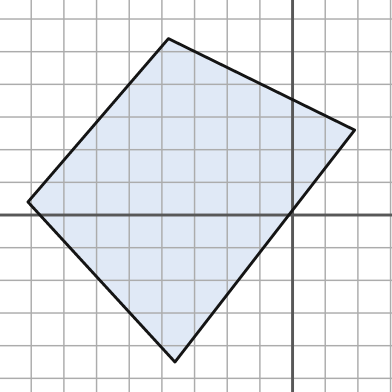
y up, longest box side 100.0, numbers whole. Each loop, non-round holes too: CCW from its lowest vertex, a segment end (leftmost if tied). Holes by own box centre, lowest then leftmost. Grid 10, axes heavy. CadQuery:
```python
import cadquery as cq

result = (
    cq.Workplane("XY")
    .moveTo(-36.0, -45.0)
    .lineTo(19.0, 26.0)
    .lineTo(-38.0, 54.0)
    .lineTo(-81.0, 4.0)
    .close()
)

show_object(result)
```